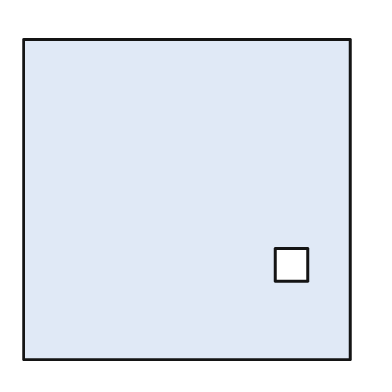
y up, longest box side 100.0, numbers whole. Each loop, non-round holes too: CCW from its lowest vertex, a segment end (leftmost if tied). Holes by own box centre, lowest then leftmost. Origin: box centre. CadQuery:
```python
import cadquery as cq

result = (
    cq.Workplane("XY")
    .moveTo(-50.0, -49.0)
    .lineTo(50.0, -49.0)
    .lineTo(50.0, 49.0)
    .lineTo(-50.0, 49.0)
    .close()
    .moveTo(27.0, -25.0)
    .lineTo(37.0, -25.0)
    .lineTo(37.0, -15.0)
    .lineTo(27.0, -15.0)
    .close()
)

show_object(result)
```